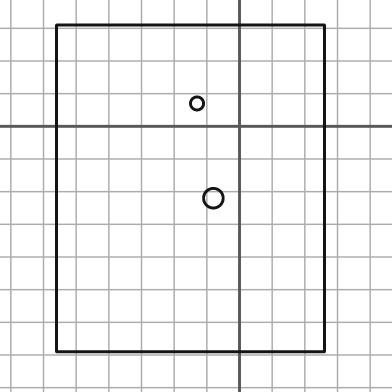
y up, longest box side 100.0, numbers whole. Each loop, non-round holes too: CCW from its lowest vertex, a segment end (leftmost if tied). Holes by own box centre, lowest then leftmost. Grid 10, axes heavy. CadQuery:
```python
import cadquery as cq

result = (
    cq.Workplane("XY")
    .moveTo(-56.0, -69.0)
    .lineTo(26.0, -69.0)
    .lineTo(26.0, 31.0)
    .lineTo(-56.0, 31.0)
    .close()
    .moveTo(-8.0, -22.0)
    .circle(3.0)
    .moveTo(-13.0, 7.0)
    .circle(2.0)
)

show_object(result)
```